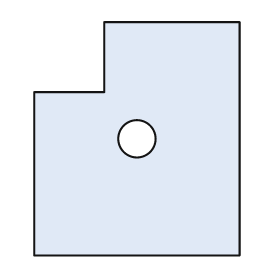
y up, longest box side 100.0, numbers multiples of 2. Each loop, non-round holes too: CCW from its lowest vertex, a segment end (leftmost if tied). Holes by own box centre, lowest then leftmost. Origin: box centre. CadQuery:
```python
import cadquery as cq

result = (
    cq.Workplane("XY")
    .moveTo(-44.0, -50.0)
    .lineTo(44.0, -50.0)
    .lineTo(44.0, 50.0)
    .lineTo(-14.0, 50.0)
    .lineTo(-14.0, 20.0)
    .lineTo(-44.0, 20.0)
    .close()
    .moveTo(0.0, 0.0)
    .circle(8.0)
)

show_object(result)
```